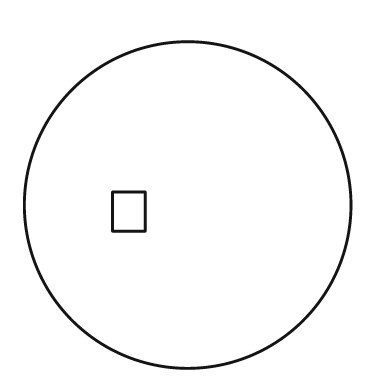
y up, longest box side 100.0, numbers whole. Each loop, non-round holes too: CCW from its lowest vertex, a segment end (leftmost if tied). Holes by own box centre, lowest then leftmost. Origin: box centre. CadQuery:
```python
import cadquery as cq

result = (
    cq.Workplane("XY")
    .moveTo(0.0, 0.0)
    .circle(50.0)
    .moveTo(-23.0, -8.0)
    .lineTo(-13.0, -8.0)
    .lineTo(-13.0, 4.0)
    .lineTo(-23.0, 4.0)
    .close()
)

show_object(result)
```